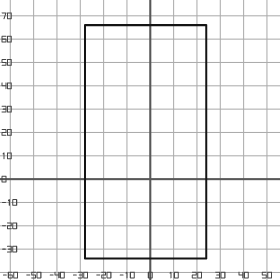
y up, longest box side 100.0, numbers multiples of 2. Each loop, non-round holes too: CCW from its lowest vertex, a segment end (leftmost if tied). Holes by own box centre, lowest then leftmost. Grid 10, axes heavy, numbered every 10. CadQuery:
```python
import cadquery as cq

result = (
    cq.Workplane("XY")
    .moveTo(-28.0, -34.0)
    .lineTo(24.0, -34.0)
    .lineTo(24.0, 66.0)
    .lineTo(-28.0, 66.0)
    .close()
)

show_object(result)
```